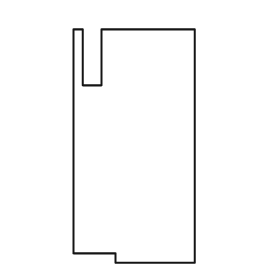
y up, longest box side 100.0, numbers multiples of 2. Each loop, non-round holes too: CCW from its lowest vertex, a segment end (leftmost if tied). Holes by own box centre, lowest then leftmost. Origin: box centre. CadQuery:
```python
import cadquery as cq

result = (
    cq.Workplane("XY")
    .moveTo(-8.0, -50.0)
    .lineTo(26.0, -50.0)
    .lineTo(26.0, 50.0)
    .lineTo(-14.0, 50.0)
    .lineTo(-14.0, 26.0)
    .lineTo(-22.0, 26.0)
    .lineTo(-22.0, 50.0)
    .lineTo(-26.0, 50.0)
    .lineTo(-26.0, -46.0)
    .lineTo(-8.0, -46.0)
    .close()
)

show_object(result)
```